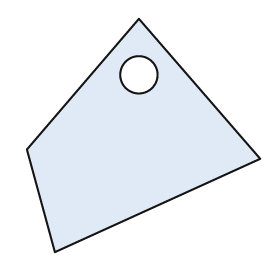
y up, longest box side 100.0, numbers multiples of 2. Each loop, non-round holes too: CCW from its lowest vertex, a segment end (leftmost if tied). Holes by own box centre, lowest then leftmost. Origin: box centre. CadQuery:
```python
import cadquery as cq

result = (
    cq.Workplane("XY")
    .moveTo(-38.0, -50.0)
    .lineTo(50.0, -10.0)
    .lineTo(-2.0, 50.0)
    .lineTo(-50.0, -6.0)
    .close()
    .moveTo(-2.0, 26.0)
    .circle(8.0)
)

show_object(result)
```